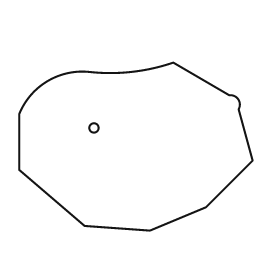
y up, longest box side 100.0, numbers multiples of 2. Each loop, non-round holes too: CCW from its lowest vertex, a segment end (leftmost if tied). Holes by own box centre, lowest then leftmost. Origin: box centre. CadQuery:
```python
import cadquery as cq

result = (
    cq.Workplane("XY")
    .moveTo(6.0, -36.0)
    .lineTo(30.0, -26.0)
    .lineTo(50.0, -6.0)
    .lineTo(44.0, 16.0)
    .threePointArc((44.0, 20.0), (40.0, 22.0))
    .lineTo(16.0, 36.0)
    .threePointArc((-2.0, 32.0), (-20.0, 32.0))
    .threePointArc((-38.0, 28.0), (-50.0, 14.0))
    .lineTo(-50.0, -10.0)
    .lineTo(-22.0, -34.0)
    .close()
    .moveTo(-18.0, 8.0)
    .circle(2.0)
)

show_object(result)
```